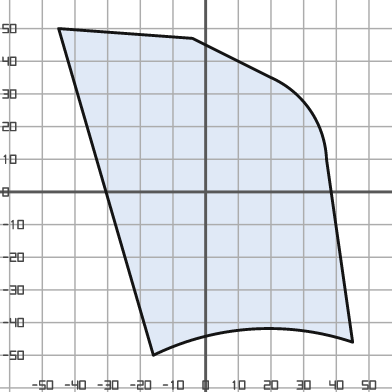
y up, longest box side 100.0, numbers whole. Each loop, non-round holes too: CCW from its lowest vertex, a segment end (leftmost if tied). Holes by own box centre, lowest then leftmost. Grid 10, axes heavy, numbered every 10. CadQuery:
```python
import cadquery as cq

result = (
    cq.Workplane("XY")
    .moveTo(-16.0, -50.0)
    .threePointArc((14.0, -42.0), (45.0, -46.0))
    .lineTo(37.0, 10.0)
    .threePointArc((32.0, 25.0), (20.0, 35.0))
    .lineTo(-4.0, 47.0)
    .lineTo(-45.0, 50.0)
    .close()
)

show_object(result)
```